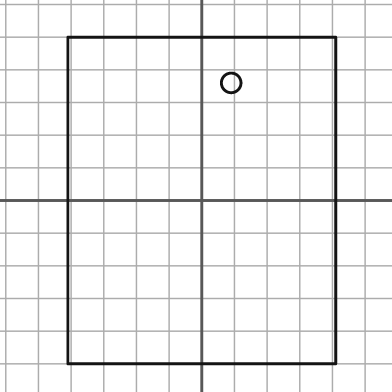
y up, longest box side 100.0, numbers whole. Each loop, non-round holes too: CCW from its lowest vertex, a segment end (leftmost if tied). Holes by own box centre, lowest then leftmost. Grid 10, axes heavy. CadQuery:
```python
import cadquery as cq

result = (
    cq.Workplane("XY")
    .moveTo(-41.0, -50.0)
    .lineTo(41.0, -50.0)
    .lineTo(41.0, 50.0)
    .lineTo(-41.0, 50.0)
    .close()
    .moveTo(9.0, 36.0)
    .circle(3.0)
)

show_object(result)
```